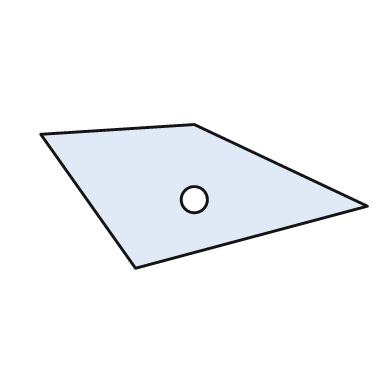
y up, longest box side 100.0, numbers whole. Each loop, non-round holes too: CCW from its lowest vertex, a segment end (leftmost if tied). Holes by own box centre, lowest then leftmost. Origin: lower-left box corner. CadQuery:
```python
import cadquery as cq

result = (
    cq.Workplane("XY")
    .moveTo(29.0, 0.0)
    .lineTo(100.0, 19.0)
    .lineTo(47.0, 44.0)
    .lineTo(0.0, 41.0)
    .close()
    .moveTo(47.0, 21.0)
    .circle(4.0)
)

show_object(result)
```